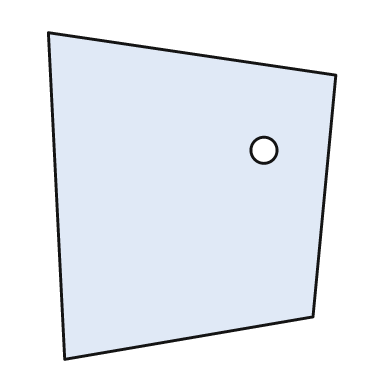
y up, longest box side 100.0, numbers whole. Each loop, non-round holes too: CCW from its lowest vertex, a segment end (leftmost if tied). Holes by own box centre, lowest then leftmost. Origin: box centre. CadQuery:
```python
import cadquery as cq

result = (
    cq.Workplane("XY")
    .moveTo(-39.0, -50.0)
    .lineTo(37.0, -37.0)
    .lineTo(44.0, 37.0)
    .lineTo(-44.0, 50.0)
    .close()
    .moveTo(22.0, 14.0)
    .circle(4.0)
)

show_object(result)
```